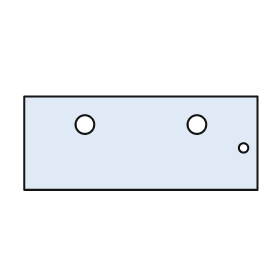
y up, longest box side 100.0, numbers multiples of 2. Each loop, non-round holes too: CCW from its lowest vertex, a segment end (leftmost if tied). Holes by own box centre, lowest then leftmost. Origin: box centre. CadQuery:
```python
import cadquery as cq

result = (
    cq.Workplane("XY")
    .moveTo(-50.0, -20.0)
    .lineTo(50.0, -20.0)
    .lineTo(50.0, 20.0)
    .lineTo(-50.0, 20.0)
    .close()
    .moveTo(44.0, -2.0)
    .circle(2.0)
    .moveTo(-24.0, 8.0)
    .circle(4.0)
    .moveTo(24.0, 8.0)
    .circle(4.0)
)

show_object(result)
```